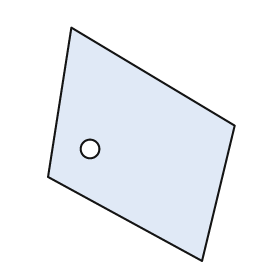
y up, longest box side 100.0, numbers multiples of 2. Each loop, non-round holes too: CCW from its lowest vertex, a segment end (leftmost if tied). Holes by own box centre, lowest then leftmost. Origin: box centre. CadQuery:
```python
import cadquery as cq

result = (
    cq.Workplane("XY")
    .moveTo(26.0, -50.0)
    .lineTo(40.0, 8.0)
    .lineTo(-30.0, 50.0)
    .lineTo(-40.0, -14.0)
    .close()
    .moveTo(-22.0, -2.0)
    .circle(4.0)
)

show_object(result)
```